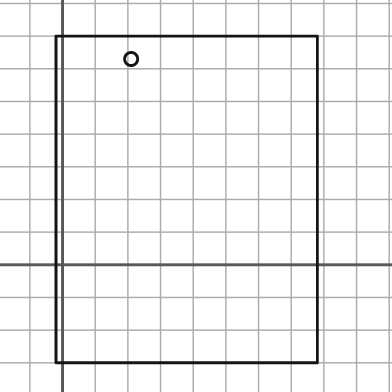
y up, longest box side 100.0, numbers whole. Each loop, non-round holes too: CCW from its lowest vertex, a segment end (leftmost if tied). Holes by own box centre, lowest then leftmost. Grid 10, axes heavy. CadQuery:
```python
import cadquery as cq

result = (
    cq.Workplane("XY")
    .moveTo(-2.0, -30.0)
    .lineTo(78.0, -30.0)
    .lineTo(78.0, 70.0)
    .lineTo(-2.0, 70.0)
    .close()
    .moveTo(21.0, 63.0)
    .circle(2.0)
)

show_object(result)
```